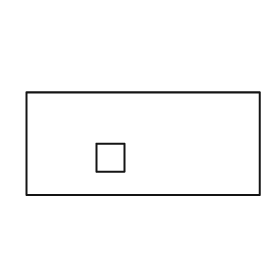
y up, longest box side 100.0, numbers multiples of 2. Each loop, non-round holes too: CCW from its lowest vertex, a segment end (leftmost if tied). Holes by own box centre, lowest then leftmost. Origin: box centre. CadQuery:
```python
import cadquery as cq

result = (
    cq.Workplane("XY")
    .moveTo(-50.0, -22.0)
    .lineTo(50.0, -22.0)
    .lineTo(50.0, 22.0)
    .lineTo(-50.0, 22.0)
    .close()
    .moveTo(-20.0, -12.0)
    .lineTo(-8.0, -12.0)
    .lineTo(-8.0, 0.0)
    .lineTo(-20.0, 0.0)
    .close()
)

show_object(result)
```